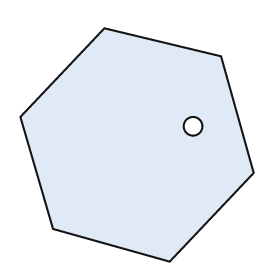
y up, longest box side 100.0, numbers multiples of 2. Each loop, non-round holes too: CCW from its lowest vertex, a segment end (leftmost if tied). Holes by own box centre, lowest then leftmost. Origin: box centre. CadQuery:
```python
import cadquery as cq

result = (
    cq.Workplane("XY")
    .moveTo(14.0, -50.0)
    .lineTo(50.0, -12.0)
    .lineTo(36.0, 38.0)
    .lineTo(-14.0, 50.0)
    .lineTo(-50.0, 12.0)
    .lineTo(-36.0, -36.0)
    .close()
    .moveTo(24.0, 8.0)
    .circle(4.0)
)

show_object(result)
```